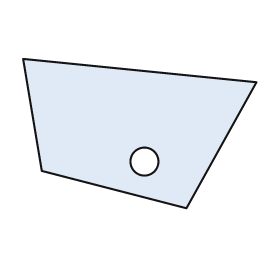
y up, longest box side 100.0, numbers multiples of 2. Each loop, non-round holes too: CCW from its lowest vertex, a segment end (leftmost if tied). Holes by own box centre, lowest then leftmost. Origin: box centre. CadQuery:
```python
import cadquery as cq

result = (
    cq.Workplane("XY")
    .moveTo(20.0, -32.0)
    .lineTo(50.0, 22.0)
    .lineTo(-50.0, 32.0)
    .lineTo(-42.0, -16.0)
    .close()
    .moveTo(2.0, -12.0)
    .circle(6.0)
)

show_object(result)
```